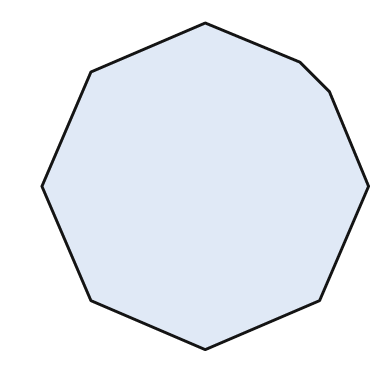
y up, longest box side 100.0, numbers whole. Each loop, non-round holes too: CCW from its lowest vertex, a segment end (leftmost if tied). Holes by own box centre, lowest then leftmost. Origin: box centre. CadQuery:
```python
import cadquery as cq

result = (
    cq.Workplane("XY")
    .moveTo(0.0, -50.0)
    .lineTo(35.0, -35.0)
    .lineTo(50.0, 0.0)
    .lineTo(38.0, 29.0)
    .lineTo(29.0, 38.0)
    .lineTo(0.0, 50.0)
    .lineTo(-35.0, 35.0)
    .lineTo(-50.0, 0.0)
    .lineTo(-35.0, -35.0)
    .close()
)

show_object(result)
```